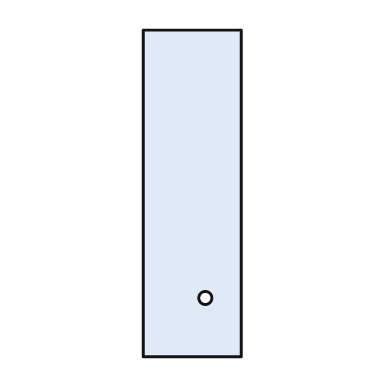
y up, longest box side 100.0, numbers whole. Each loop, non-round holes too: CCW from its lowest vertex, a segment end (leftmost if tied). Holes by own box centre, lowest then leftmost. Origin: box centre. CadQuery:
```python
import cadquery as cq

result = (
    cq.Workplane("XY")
    .moveTo(-15.0, -50.0)
    .lineTo(15.0, -50.0)
    .lineTo(15.0, 50.0)
    .lineTo(-15.0, 50.0)
    .close()
    .moveTo(4.0, -32.0)
    .circle(2.0)
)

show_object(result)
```